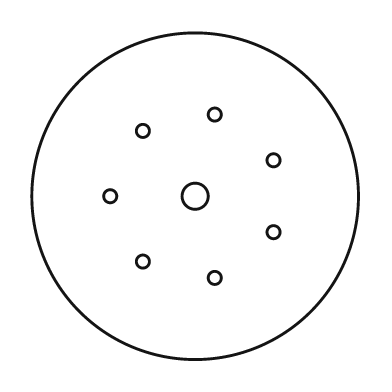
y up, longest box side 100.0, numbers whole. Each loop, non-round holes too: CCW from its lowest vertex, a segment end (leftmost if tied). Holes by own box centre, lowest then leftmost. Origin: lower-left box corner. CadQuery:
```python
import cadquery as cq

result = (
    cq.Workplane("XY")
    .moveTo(50.0, 50.0)
    .circle(50.0)
    .moveTo(56.0, 25.0)
    .circle(2.0)
    .moveTo(34.0, 30.0)
    .circle(2.0)
    .moveTo(74.0, 39.0)
    .circle(2.0)
    .moveTo(24.0, 50.0)
    .circle(2.0)
    .moveTo(50.0, 50.0)
    .circle(4.0)
    .moveTo(74.0, 61.0)
    .circle(2.0)
    .moveTo(34.0, 70.0)
    .circle(2.0)
    .moveTo(56.0, 75.0)
    .circle(2.0)
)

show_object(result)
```